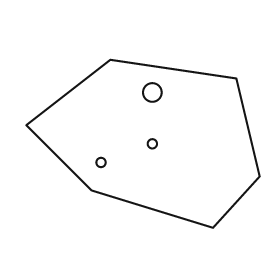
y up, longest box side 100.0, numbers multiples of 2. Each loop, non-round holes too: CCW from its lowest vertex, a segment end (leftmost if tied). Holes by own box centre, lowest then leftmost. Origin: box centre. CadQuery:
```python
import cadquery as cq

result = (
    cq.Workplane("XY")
    .moveTo(30.0, -36.0)
    .lineTo(50.0, -14.0)
    .lineTo(40.0, 28.0)
    .lineTo(-14.0, 36.0)
    .lineTo(-50.0, 8.0)
    .lineTo(-22.0, -20.0)
    .close()
    .moveTo(-18.0, -8.0)
    .circle(2.0)
    .moveTo(4.0, 0.0)
    .circle(2.0)
    .moveTo(4.0, 22.0)
    .circle(4.0)
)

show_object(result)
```